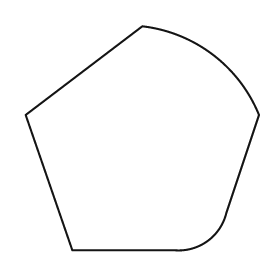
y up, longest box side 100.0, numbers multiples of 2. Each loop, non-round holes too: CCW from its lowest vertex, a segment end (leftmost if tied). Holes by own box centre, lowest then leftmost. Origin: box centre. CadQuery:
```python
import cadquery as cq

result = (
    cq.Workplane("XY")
    .moveTo(-30.0, -48.0)
    .lineTo(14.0, -48.0)
    .threePointArc((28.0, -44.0), (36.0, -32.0))
    .lineTo(50.0, 10.0)
    .threePointArc((30.0, 36.0), (0.0, 48.0))
    .lineTo(-50.0, 10.0)
    .close()
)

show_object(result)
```